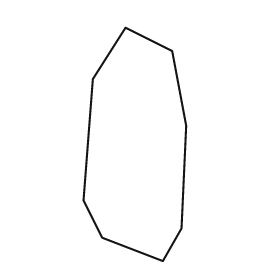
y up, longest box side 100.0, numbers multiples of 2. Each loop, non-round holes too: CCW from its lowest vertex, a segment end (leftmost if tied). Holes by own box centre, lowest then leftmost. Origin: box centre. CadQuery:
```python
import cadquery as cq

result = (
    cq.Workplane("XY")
    .moveTo(12.0, -50.0)
    .lineTo(20.0, -36.0)
    .lineTo(22.0, 8.0)
    .lineTo(16.0, 40.0)
    .lineTo(-4.0, 50.0)
    .lineTo(-18.0, 28.0)
    .lineTo(-22.0, -24.0)
    .lineTo(-14.0, -40.0)
    .close()
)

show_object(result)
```